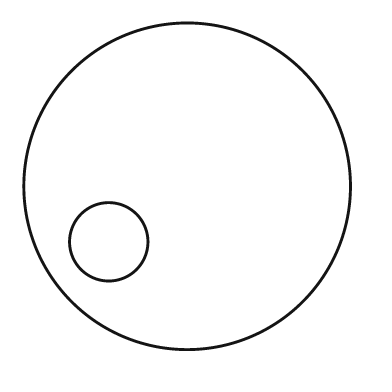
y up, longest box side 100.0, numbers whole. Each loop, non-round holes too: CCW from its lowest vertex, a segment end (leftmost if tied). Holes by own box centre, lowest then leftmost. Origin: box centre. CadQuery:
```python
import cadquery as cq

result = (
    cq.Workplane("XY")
    .moveTo(0.0, 0.0)
    .circle(50.0)
    .moveTo(-24.0, -17.0)
    .circle(12.0)
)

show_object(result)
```